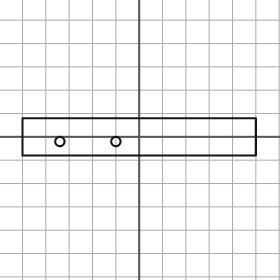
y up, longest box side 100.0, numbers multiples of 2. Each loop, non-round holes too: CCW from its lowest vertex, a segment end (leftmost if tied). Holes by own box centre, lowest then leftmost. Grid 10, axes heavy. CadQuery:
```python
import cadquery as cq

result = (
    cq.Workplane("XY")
    .moveTo(-50.0, -8.0)
    .lineTo(50.0, -8.0)
    .lineTo(50.0, 8.0)
    .lineTo(-50.0, 8.0)
    .close()
    .moveTo(-34.0, -2.0)
    .circle(2.0)
    .moveTo(-10.0, -2.0)
    .circle(2.0)
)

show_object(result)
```